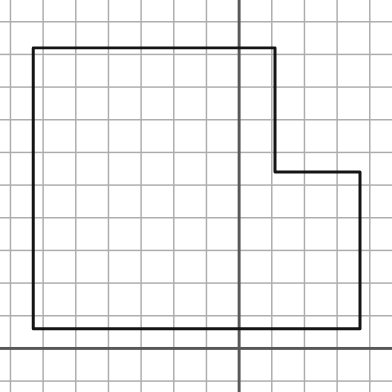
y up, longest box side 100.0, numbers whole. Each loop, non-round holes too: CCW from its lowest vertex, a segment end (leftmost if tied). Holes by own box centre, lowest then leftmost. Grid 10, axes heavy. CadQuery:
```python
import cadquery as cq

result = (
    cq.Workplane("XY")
    .moveTo(-63.0, 6.0)
    .lineTo(37.0, 6.0)
    .lineTo(37.0, 54.0)
    .lineTo(11.0, 54.0)
    .lineTo(11.0, 92.0)
    .lineTo(-63.0, 92.0)
    .close()
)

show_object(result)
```